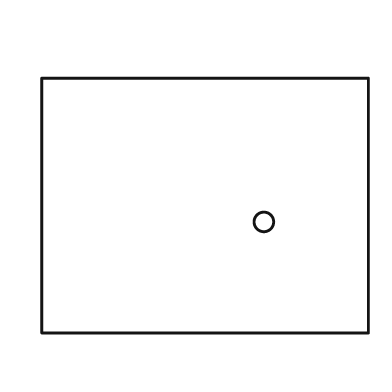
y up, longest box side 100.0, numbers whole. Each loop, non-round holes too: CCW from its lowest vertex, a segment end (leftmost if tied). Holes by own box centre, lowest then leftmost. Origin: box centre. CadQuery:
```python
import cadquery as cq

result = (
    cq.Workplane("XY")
    .moveTo(-50.0, -39.0)
    .lineTo(50.0, -39.0)
    .lineTo(50.0, 39.0)
    .lineTo(-50.0, 39.0)
    .close()
    .moveTo(18.0, -5.0)
    .circle(3.0)
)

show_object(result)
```